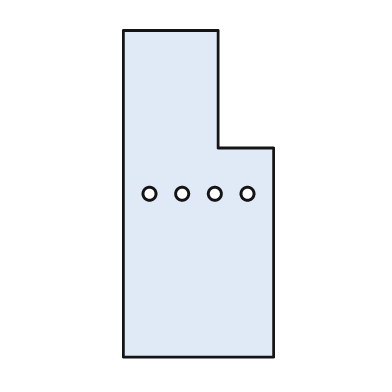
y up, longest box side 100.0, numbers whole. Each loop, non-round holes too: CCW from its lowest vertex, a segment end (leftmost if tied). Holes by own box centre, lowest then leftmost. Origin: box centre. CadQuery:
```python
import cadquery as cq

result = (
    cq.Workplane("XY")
    .moveTo(-23.0, -50.0)
    .lineTo(23.0, -50.0)
    .lineTo(23.0, 14.0)
    .lineTo(6.0, 14.0)
    .lineTo(6.0, 50.0)
    .lineTo(-23.0, 50.0)
    .close()
    .moveTo(-15.0, 0.0)
    .circle(2.0)
    .moveTo(-5.0, 0.0)
    .circle(2.0)
    .moveTo(5.0, 0.0)
    .circle(2.0)
    .moveTo(15.0, 0.0)
    .circle(2.0)
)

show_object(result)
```